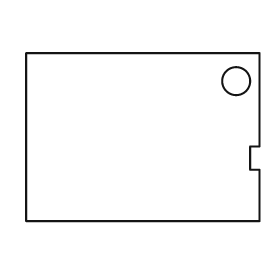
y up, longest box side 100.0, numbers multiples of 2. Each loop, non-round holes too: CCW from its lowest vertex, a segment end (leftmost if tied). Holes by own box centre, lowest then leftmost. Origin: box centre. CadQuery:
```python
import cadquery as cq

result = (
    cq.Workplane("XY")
    .moveTo(-50.0, -36.0)
    .lineTo(50.0, -36.0)
    .lineTo(50.0, -14.0)
    .lineTo(46.0, -14.0)
    .lineTo(46.0, -4.0)
    .lineTo(50.0, -4.0)
    .lineTo(50.0, 36.0)
    .lineTo(-50.0, 36.0)
    .close()
    .moveTo(40.0, 24.0)
    .circle(6.0)
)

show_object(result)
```